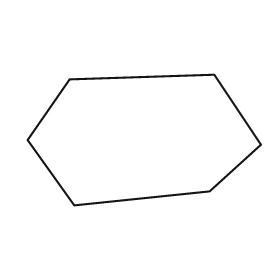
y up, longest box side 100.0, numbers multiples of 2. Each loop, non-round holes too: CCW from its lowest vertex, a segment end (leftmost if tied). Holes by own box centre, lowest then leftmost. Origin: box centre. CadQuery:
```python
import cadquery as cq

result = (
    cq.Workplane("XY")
    .moveTo(-30.0, -28.0)
    .lineTo(28.0, -22.0)
    .lineTo(50.0, -2.0)
    .lineTo(30.0, 28.0)
    .lineTo(-32.0, 26.0)
    .lineTo(-50.0, 0.0)
    .close()
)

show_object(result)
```